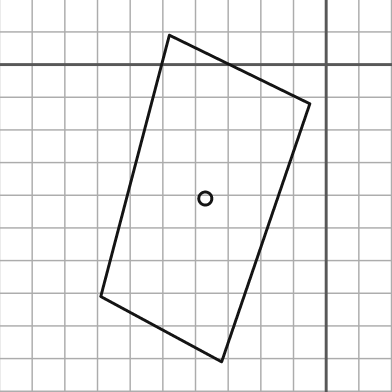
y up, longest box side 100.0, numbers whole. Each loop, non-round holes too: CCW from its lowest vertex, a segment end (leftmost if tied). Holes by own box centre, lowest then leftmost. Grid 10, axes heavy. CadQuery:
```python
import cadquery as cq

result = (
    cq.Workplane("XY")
    .moveTo(-32.0, -91.0)
    .lineTo(-5.0, -12.0)
    .lineTo(-48.0, 9.0)
    .lineTo(-69.0, -71.0)
    .close()
    .moveTo(-37.0, -41.0)
    .circle(2.0)
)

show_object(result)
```